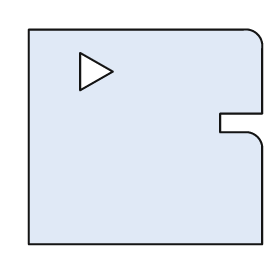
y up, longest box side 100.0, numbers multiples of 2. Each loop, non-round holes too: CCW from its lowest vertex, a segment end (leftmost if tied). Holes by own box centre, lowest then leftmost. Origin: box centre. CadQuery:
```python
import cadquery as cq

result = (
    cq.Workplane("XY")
    .moveTo(-50.0, -46.0)
    .lineTo(50.0, -46.0)
    .lineTo(50.0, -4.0)
    .threePointArc((48.0, 0.0), (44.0, 2.0))
    .lineTo(32.0, 2.0)
    .lineTo(32.0, 10.0)
    .lineTo(50.0, 10.0)
    .lineTo(50.0, 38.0)
    .threePointArc((48.0, 44.0), (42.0, 46.0))
    .lineTo(-50.0, 46.0)
    .close()
    .moveTo(-28.0, 20.0)
    .lineTo(-14.0, 28.0)
    .lineTo(-28.0, 36.0)
    .close()
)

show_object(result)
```